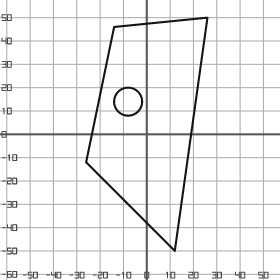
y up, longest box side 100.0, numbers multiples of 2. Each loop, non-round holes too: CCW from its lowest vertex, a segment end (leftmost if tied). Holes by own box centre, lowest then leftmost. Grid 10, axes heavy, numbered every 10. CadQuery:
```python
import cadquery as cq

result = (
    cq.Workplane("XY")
    .moveTo(12.0, -50.0)
    .lineTo(26.0, 50.0)
    .lineTo(-14.0, 46.0)
    .lineTo(-26.0, -12.0)
    .close()
    .moveTo(-8.0, 14.0)
    .circle(6.0)
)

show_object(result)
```